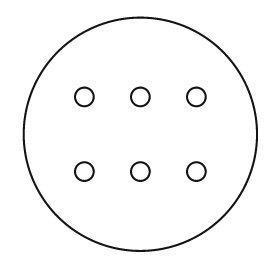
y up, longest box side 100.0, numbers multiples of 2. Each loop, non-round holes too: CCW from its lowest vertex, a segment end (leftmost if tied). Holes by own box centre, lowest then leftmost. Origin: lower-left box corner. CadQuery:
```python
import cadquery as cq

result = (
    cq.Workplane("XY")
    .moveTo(50.0, 50.0)
    .circle(50.0)
    .moveTo(26.0, 34.0)
    .circle(4.0)
    .moveTo(50.0, 34.0)
    .circle(4.0)
    .moveTo(74.0, 34.0)
    .circle(4.0)
    .moveTo(26.0, 66.0)
    .circle(4.0)
    .moveTo(50.0, 66.0)
    .circle(4.0)
    .moveTo(74.0, 66.0)
    .circle(4.0)
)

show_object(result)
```